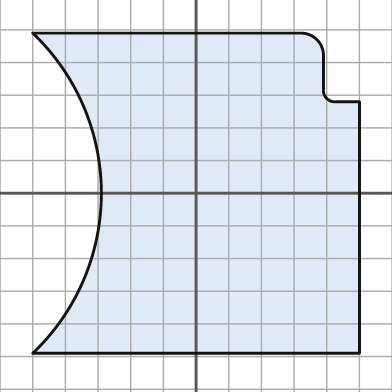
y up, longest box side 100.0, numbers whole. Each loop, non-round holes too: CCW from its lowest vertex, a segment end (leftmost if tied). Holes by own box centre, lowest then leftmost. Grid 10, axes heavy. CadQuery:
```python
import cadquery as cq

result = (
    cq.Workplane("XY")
    .moveTo(-50.0, -49.0)
    .lineTo(50.0, -49.0)
    .lineTo(50.0, 28.0)
    .lineTo(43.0, 28.0)
    .threePointArc((40.0, 29.0), (39.0, 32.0))
    .lineTo(39.0, 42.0)
    .threePointArc((37.0, 47.0), (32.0, 49.0))
    .lineTo(-50.0, 49.0)
    .threePointArc((-29.0, 0.0), (-50.0, -49.0))
    .close()
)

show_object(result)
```